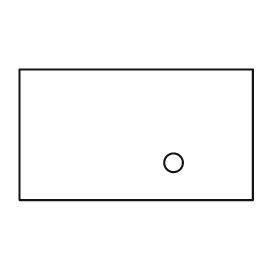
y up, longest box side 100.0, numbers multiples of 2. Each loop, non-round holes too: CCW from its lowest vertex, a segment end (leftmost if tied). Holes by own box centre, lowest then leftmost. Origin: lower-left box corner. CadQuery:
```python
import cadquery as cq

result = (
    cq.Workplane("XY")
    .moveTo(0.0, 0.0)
    .lineTo(100.0, 0.0)
    .lineTo(100.0, 56.0)
    .lineTo(0.0, 56.0)
    .close()
    .moveTo(66.0, 16.0)
    .circle(4.0)
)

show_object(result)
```